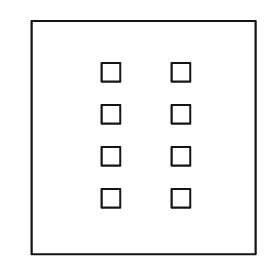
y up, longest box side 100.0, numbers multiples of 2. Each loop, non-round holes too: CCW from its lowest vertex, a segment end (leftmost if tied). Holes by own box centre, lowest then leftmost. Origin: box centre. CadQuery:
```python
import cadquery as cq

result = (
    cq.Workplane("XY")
    .moveTo(-48.0, -50.0)
    .lineTo(48.0, -50.0)
    .lineTo(48.0, 50.0)
    .lineTo(-48.0, 50.0)
    .close()
    .moveTo(-18.0, -30.0)
    .lineTo(-10.0, -30.0)
    .lineTo(-10.0, -22.0)
    .lineTo(-18.0, -22.0)
    .close()
    .moveTo(12.0, -30.0)
    .lineTo(20.0, -30.0)
    .lineTo(20.0, -22.0)
    .lineTo(12.0, -22.0)
    .close()
    .moveTo(-18.0, -12.0)
    .lineTo(-10.0, -12.0)
    .lineTo(-10.0, -4.0)
    .lineTo(-18.0, -4.0)
    .close()
    .moveTo(12.0, -12.0)
    .lineTo(20.0, -12.0)
    .lineTo(20.0, -4.0)
    .lineTo(12.0, -4.0)
    .close()
    .moveTo(-18.0, 6.0)
    .lineTo(-10.0, 6.0)
    .lineTo(-10.0, 14.0)
    .lineTo(-18.0, 14.0)
    .close()
    .moveTo(12.0, 6.0)
    .lineTo(20.0, 6.0)
    .lineTo(20.0, 14.0)
    .lineTo(12.0, 14.0)
    .close()
    .moveTo(-18.0, 24.0)
    .lineTo(-10.0, 24.0)
    .lineTo(-10.0, 32.0)
    .lineTo(-18.0, 32.0)
    .close()
    .moveTo(12.0, 24.0)
    .lineTo(20.0, 24.0)
    .lineTo(20.0, 32.0)
    .lineTo(12.0, 32.0)
    .close()
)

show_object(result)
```